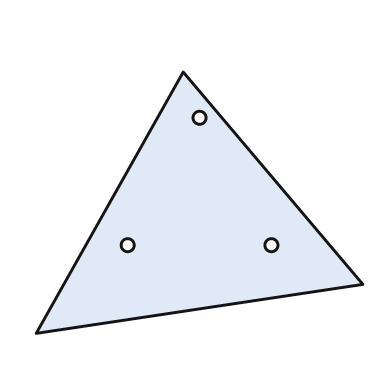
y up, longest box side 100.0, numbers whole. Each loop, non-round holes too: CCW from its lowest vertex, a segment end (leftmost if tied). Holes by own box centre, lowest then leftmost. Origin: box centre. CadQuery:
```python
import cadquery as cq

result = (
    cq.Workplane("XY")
    .moveTo(-50.0, -40.0)
    .lineTo(50.0, -25.0)
    .lineTo(-5.0, 40.0)
    .close()
    .moveTo(-22.0, -13.0)
    .circle(2.0)
    .moveTo(22.0, -13.0)
    .circle(2.0)
    .moveTo(0.0, 26.0)
    .circle(2.0)
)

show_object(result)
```